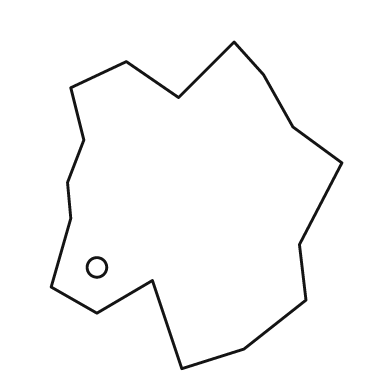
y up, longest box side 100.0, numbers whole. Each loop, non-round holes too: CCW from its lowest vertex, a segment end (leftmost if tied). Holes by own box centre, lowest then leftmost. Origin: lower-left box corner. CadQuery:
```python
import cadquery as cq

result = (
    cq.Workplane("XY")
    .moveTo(40.0, 0.0)
    .lineTo(59.0, 6.0)
    .lineTo(78.0, 21.0)
    .lineTo(76.0, 38.0)
    .lineTo(89.0, 63.0)
    .lineTo(74.0, 74.0)
    .lineTo(65.0, 90.0)
    .lineTo(56.0, 100.0)
    .lineTo(39.0, 83.0)
    .lineTo(23.0, 94.0)
    .lineTo(6.0, 86.0)
    .lineTo(10.0, 70.0)
    .lineTo(5.0, 57.0)
    .lineTo(6.0, 46.0)
    .lineTo(0.0, 25.0)
    .lineTo(14.0, 17.0)
    .lineTo(31.0, 27.0)
    .close()
    .moveTo(14.0, 31.0)
    .circle(3.0)
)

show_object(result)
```